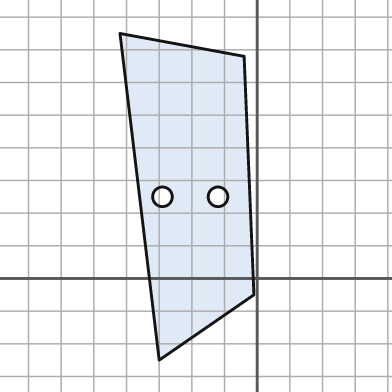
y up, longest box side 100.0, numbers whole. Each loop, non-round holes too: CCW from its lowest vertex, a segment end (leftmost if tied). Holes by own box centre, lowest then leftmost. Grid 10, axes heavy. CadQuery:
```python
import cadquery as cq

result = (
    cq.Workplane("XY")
    .moveTo(-30.0, -25.0)
    .lineTo(-1.0, -5.0)
    .lineTo(-4.0, 68.0)
    .lineTo(-42.0, 75.0)
    .close()
    .moveTo(-29.0, 25.0)
    .circle(3.0)
    .moveTo(-12.0, 25.0)
    .circle(3.0)
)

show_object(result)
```